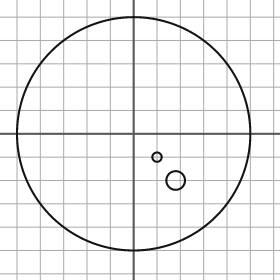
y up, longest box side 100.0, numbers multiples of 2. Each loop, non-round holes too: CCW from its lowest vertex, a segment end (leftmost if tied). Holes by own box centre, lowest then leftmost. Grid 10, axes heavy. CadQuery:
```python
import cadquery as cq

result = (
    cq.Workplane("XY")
    .moveTo(0.0, 0.0)
    .circle(50.0)
    .moveTo(18.0, -20.0)
    .circle(4.0)
    .moveTo(10.0, -10.0)
    .circle(2.0)
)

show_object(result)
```